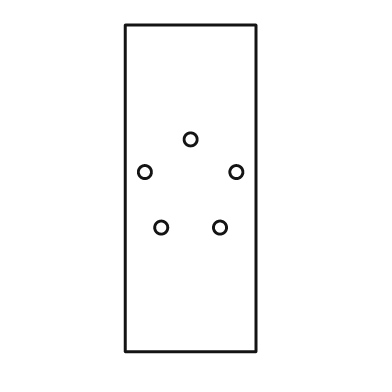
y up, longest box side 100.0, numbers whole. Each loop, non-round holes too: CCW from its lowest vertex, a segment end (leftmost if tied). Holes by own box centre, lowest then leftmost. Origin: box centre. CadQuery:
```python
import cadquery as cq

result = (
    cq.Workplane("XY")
    .moveTo(-20.0, -50.0)
    .lineTo(20.0, -50.0)
    .lineTo(20.0, 50.0)
    .lineTo(-20.0, 50.0)
    .close()
    .moveTo(-9.0, -12.0)
    .circle(2.0)
    .moveTo(9.0, -12.0)
    .circle(2.0)
    .moveTo(-14.0, 5.0)
    .circle(2.0)
    .moveTo(14.0, 5.0)
    .circle(2.0)
    .moveTo(0.0, 15.0)
    .circle(2.0)
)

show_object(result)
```